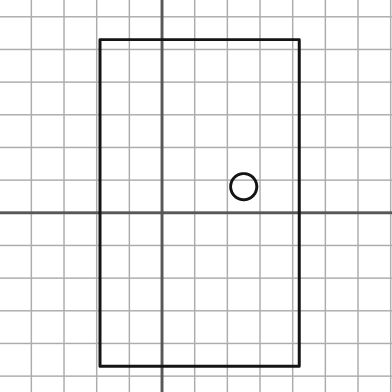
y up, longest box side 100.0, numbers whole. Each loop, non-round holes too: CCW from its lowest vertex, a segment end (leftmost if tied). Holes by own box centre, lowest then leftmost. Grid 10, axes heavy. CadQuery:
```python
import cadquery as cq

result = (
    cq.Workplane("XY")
    .moveTo(-19.0, -47.0)
    .lineTo(42.0, -47.0)
    .lineTo(42.0, 53.0)
    .lineTo(-19.0, 53.0)
    .close()
    .moveTo(25.0, 8.0)
    .circle(4.0)
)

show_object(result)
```